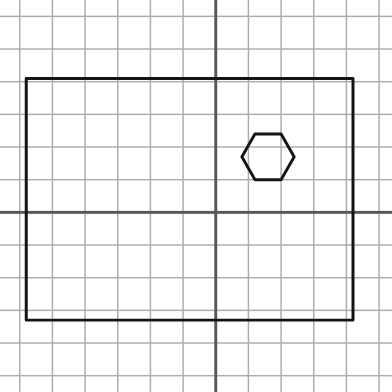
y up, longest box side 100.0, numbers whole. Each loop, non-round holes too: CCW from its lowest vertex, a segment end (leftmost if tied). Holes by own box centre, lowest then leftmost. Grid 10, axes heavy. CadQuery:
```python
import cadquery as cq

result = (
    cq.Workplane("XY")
    .moveTo(-58.0, -33.0)
    .lineTo(42.0, -33.0)
    .lineTo(42.0, 41.0)
    .lineTo(-58.0, 41.0)
    .close()
    .moveTo(12.0, 10.0)
    .lineTo(20.0, 10.0)
    .lineTo(24.0, 17.0)
    .lineTo(20.0, 24.0)
    .lineTo(12.0, 24.0)
    .lineTo(8.0, 17.0)
    .close()
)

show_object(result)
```